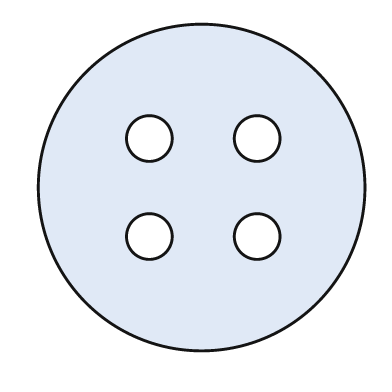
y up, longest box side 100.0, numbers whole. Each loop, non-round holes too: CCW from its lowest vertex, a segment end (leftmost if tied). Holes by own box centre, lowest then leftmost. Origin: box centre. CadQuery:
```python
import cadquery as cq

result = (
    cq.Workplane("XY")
    .moveTo(0.0, 0.0)
    .circle(50.0)
    .moveTo(-16.0, -15.0)
    .circle(7.0)
    .moveTo(17.0, -15.0)
    .circle(7.0)
    .moveTo(-16.0, 15.0)
    .circle(7.0)
    .moveTo(17.0, 15.0)
    .circle(7.0)
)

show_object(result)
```